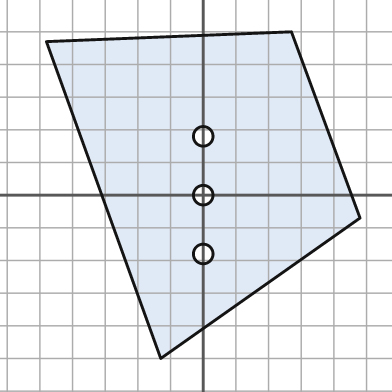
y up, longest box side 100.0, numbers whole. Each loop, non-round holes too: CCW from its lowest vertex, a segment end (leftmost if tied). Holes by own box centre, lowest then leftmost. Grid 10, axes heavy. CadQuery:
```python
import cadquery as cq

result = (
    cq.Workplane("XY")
    .moveTo(-13.0, -50.0)
    .lineTo(48.0, -7.0)
    .lineTo(27.0, 50.0)
    .lineTo(-48.0, 47.0)
    .close()
    .moveTo(0.0, -18.0)
    .circle(3.0)
    .moveTo(0.0, 0.0)
    .circle(3.0)
    .moveTo(0.0, 18.0)
    .circle(3.0)
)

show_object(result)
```